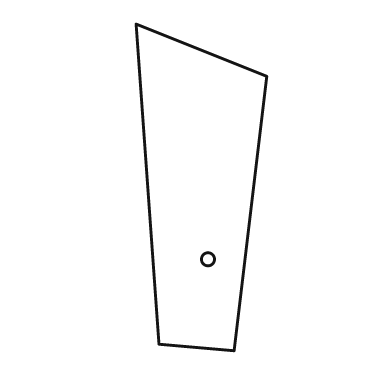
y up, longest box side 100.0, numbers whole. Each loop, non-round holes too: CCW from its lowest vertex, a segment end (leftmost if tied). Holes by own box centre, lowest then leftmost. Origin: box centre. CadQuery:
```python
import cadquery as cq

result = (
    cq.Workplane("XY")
    .moveTo(10.0, -50.0)
    .lineTo(20.0, 34.0)
    .lineTo(-20.0, 50.0)
    .lineTo(-13.0, -48.0)
    .close()
    .moveTo(2.0, -22.0)
    .circle(2.0)
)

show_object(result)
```